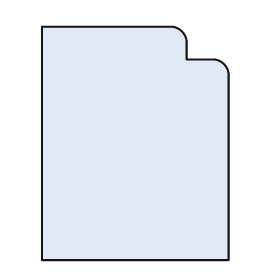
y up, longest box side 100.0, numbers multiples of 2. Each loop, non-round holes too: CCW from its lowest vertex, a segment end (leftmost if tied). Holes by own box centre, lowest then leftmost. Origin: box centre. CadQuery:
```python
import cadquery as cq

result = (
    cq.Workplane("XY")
    .moveTo(-40.0, -50.0)
    .lineTo(40.0, -50.0)
    .lineTo(40.0, 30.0)
    .threePointArc((38.0, 34.0), (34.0, 36.0))
    .lineTo(22.0, 36.0)
    .lineTo(22.0, 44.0)
    .threePointArc((20.0, 48.0), (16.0, 50.0))
    .lineTo(-40.0, 50.0)
    .close()
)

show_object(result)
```